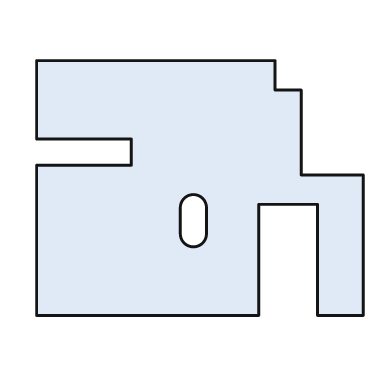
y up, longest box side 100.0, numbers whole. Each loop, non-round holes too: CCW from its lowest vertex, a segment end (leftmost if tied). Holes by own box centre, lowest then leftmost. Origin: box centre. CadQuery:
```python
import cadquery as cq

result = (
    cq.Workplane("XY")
    .moveTo(-50.0, -39.0)
    .lineTo(18.0, -39.0)
    .lineTo(18.0, -5.0)
    .lineTo(36.0, -5.0)
    .lineTo(36.0, -39.0)
    .lineTo(50.0, -39.0)
    .lineTo(50.0, 4.0)
    .lineTo(31.0, 4.0)
    .lineTo(31.0, 30.0)
    .lineTo(23.0, 30.0)
    .lineTo(23.0, 39.0)
    .lineTo(-50.0, 39.0)
    .lineTo(-50.0, 15.0)
    .lineTo(-21.0, 15.0)
    .lineTo(-21.0, 7.0)
    .lineTo(-50.0, 7.0)
    .close()
    .moveTo(-6.0, -14.0)
    .threePointArc((-2.0, -18.0), (2.0, -14.0))
    .lineTo(2.0, -6.0)
    .threePointArc((-2.0, -2.0), (-6.0, -6.0))
    .close()
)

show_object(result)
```